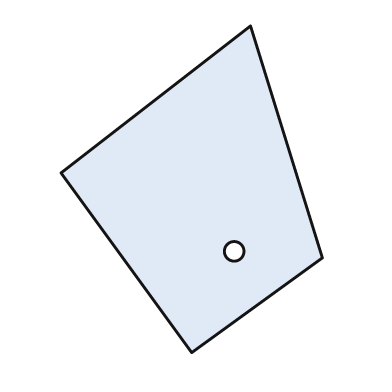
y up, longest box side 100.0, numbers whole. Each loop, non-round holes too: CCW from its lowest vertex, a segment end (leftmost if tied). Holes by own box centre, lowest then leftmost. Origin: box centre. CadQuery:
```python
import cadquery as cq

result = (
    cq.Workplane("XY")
    .moveTo(0.0, -50.0)
    .lineTo(40.0, -21.0)
    .lineTo(18.0, 50.0)
    .lineTo(-40.0, 5.0)
    .close()
    .moveTo(13.0, -19.0)
    .circle(3.0)
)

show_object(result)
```